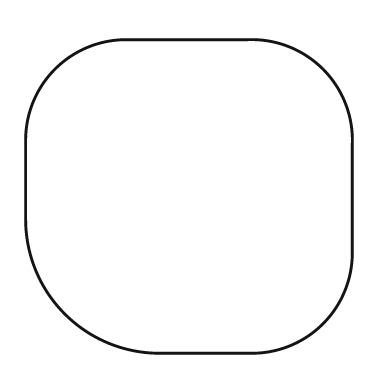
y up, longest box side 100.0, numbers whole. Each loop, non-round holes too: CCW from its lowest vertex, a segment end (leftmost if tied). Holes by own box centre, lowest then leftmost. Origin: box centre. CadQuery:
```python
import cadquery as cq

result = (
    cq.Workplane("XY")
    .moveTo(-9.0, -48.0)
    .lineTo(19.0, -48.0)
    .threePointArc((41.0, -39.0), (50.0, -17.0))
    .lineTo(50.0, 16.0)
    .threePointArc((41.0, 39.0), (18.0, 48.0))
    .lineTo(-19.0, 48.0)
    .threePointArc((-41.0, 39.0), (-50.0, 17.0))
    .lineTo(-50.0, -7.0)
    .threePointArc((-38.0, -36.0), (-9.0, -48.0))
    .close()
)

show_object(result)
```